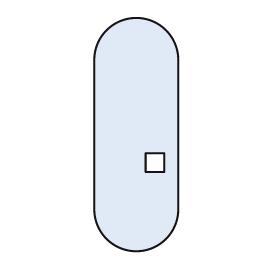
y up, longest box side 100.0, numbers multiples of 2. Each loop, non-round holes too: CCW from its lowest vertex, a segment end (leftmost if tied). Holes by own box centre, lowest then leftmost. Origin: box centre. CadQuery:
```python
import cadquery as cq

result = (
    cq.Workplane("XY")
    .moveTo(-18.0, -32.0)
    .threePointArc((0.0, -50.0), (18.0, -32.0))
    .lineTo(18.0, 32.0)
    .threePointArc((0.0, 50.0), (-18.0, 32.0))
    .close()
    .moveTo(4.0, -16.0)
    .lineTo(12.0, -16.0)
    .lineTo(12.0, -8.0)
    .lineTo(4.0, -8.0)
    .close()
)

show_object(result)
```